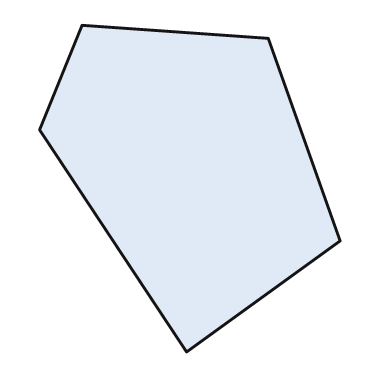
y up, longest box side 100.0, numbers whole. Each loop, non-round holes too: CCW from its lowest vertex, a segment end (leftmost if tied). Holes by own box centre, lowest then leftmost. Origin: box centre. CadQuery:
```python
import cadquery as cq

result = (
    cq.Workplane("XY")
    .moveTo(-1.0, -50.0)
    .lineTo(46.0, -16.0)
    .lineTo(24.0, 46.0)
    .lineTo(-33.0, 50.0)
    .lineTo(-46.0, 18.0)
    .close()
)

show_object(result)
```